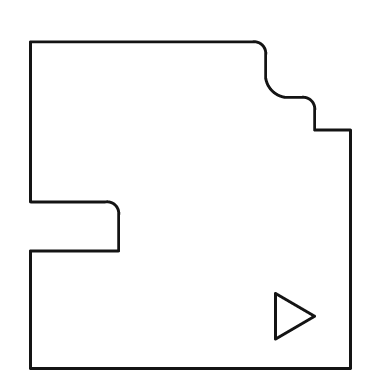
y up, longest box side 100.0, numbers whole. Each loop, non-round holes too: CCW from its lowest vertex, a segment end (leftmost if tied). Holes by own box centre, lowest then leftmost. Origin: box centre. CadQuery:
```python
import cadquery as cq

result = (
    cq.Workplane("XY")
    .moveTo(-49.0, -50.0)
    .lineTo(49.0, -50.0)
    .lineTo(49.0, 23.0)
    .lineTo(38.0, 23.0)
    .lineTo(38.0, 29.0)
    .threePointArc((37.0, 32.0), (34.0, 33.0))
    .lineTo(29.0, 33.0)
    .threePointArc((25.0, 35.0), (23.0, 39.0))
    .lineTo(23.0, 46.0)
    .threePointArc((22.0, 49.0), (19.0, 50.0))
    .lineTo(-49.0, 50.0)
    .lineTo(-49.0, 1.0)
    .lineTo(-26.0, 1.0)
    .threePointArc((-23.0, 0.0), (-22.0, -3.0))
    .lineTo(-22.0, -14.0)
    .lineTo(-49.0, -14.0)
    .close()
    .moveTo(26.0, -41.0)
    .lineTo(38.0, -34.0)
    .lineTo(26.0, -27.0)
    .close()
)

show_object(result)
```